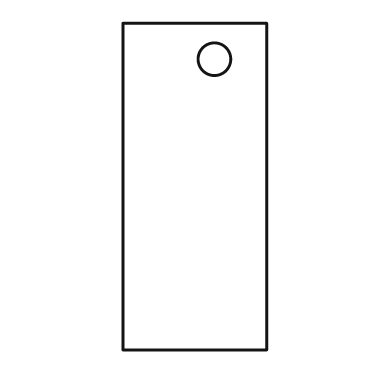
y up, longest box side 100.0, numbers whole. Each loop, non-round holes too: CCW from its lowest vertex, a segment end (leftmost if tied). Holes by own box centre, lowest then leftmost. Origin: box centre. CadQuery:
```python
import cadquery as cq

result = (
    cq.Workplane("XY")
    .moveTo(-22.0, -50.0)
    .lineTo(22.0, -50.0)
    .lineTo(22.0, 50.0)
    .lineTo(-22.0, 50.0)
    .close()
    .moveTo(6.0, 39.0)
    .circle(5.0)
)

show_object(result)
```